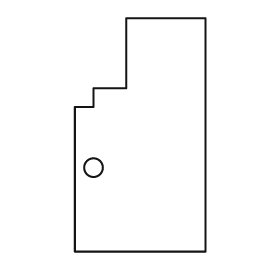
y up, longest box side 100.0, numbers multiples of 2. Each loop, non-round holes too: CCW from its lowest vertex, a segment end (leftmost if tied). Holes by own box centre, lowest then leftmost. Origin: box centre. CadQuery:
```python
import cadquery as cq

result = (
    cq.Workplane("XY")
    .moveTo(-28.0, -50.0)
    .lineTo(28.0, -50.0)
    .lineTo(28.0, 50.0)
    .lineTo(-6.0, 50.0)
    .lineTo(-6.0, 20.0)
    .lineTo(-20.0, 20.0)
    .lineTo(-20.0, 12.0)
    .lineTo(-28.0, 12.0)
    .close()
    .moveTo(-20.0, -14.0)
    .circle(4.0)
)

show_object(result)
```